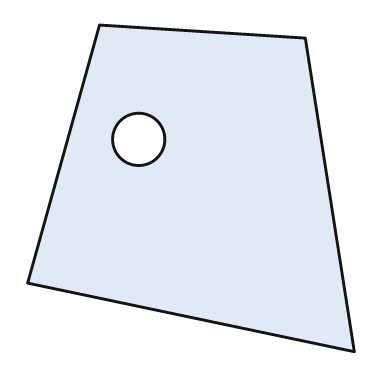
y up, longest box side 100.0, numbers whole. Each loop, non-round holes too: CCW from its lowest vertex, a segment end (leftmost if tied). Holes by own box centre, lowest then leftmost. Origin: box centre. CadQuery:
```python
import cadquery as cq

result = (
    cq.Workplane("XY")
    .moveTo(50.0, -50.0)
    .lineTo(35.0, 46.0)
    .lineTo(-28.0, 50.0)
    .lineTo(-50.0, -29.0)
    .close()
    .moveTo(-16.0, 15.0)
    .circle(8.0)
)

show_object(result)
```